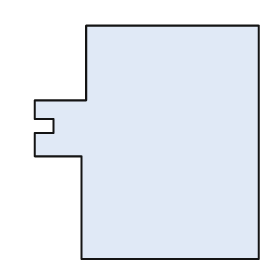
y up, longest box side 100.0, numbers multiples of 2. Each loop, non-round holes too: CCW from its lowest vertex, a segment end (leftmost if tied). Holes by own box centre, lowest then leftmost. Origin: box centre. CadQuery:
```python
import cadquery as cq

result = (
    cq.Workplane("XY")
    .moveTo(-28.0, -50.0)
    .lineTo(48.0, -50.0)
    .lineTo(48.0, 50.0)
    .lineTo(-26.0, 50.0)
    .lineTo(-26.0, 18.0)
    .lineTo(-48.0, 18.0)
    .lineTo(-48.0, 10.0)
    .lineTo(-40.0, 10.0)
    .lineTo(-40.0, 4.0)
    .lineTo(-48.0, 4.0)
    .lineTo(-48.0, -6.0)
    .lineTo(-28.0, -6.0)
    .close()
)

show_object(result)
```